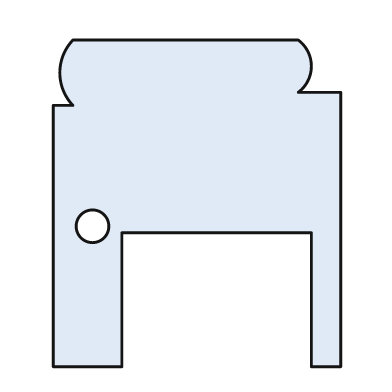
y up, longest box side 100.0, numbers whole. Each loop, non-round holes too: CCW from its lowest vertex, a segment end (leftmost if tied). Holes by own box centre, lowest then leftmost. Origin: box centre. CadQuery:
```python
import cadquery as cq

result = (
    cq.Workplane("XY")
    .moveTo(-44.0, -50.0)
    .lineTo(-23.0, -50.0)
    .lineTo(-23.0, -9.0)
    .lineTo(35.0, -9.0)
    .lineTo(35.0, -50.0)
    .lineTo(44.0, -50.0)
    .lineTo(44.0, 34.0)
    .lineTo(31.0, 34.0)
    .threePointArc((35.0, 42.0), (31.0, 50.0))
    .lineTo(-38.0, 50.0)
    .threePointArc((-42.0, 40.0), (-38.0, 30.0))
    .lineTo(-44.0, 30.0)
    .close()
    .moveTo(-32.0, -7.0)
    .circle(5.0)
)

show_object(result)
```